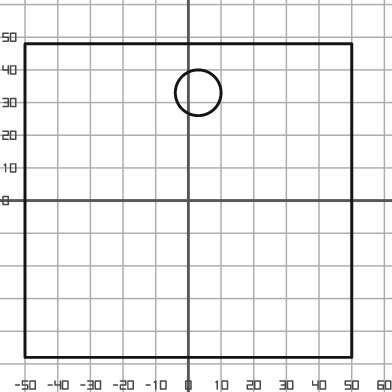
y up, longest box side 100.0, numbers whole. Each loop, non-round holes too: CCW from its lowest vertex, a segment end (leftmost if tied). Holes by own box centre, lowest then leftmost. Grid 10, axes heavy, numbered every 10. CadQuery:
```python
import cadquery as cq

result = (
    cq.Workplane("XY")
    .moveTo(-50.0, -48.0)
    .lineTo(50.0, -48.0)
    .lineTo(50.0, 48.0)
    .lineTo(-50.0, 48.0)
    .close()
    .moveTo(3.0, 33.0)
    .circle(7.0)
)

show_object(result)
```